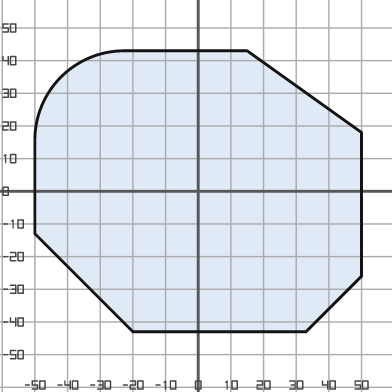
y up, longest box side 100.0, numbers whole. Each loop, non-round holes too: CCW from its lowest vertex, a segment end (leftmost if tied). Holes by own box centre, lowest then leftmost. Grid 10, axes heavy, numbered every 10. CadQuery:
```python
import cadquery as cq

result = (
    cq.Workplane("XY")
    .moveTo(-20.0, -43.0)
    .lineTo(33.0, -43.0)
    .lineTo(50.0, -26.0)
    .lineTo(50.0, 18.0)
    .lineTo(15.0, 43.0)
    .lineTo(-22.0, 43.0)
    .threePointArc((-42.0, 35.0), (-50.0, 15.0))
    .lineTo(-50.0, -13.0)
    .close()
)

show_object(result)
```